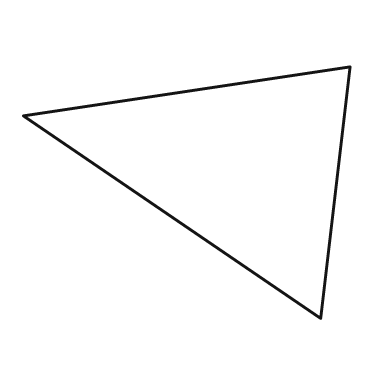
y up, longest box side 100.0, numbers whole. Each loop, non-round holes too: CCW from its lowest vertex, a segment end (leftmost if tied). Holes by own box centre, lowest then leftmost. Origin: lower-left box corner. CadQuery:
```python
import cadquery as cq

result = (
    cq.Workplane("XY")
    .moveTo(91.0, 0.0)
    .lineTo(100.0, 77.0)
    .lineTo(0.0, 62.0)
    .close()
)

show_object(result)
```